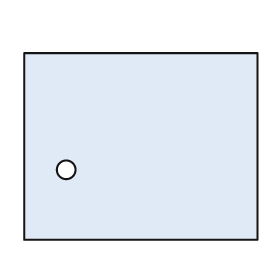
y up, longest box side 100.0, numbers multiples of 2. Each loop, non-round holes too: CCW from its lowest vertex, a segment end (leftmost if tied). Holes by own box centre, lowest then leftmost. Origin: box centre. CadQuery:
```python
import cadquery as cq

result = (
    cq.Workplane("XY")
    .moveTo(-50.0, -40.0)
    .lineTo(50.0, -40.0)
    .lineTo(50.0, 40.0)
    .lineTo(-50.0, 40.0)
    .close()
    .moveTo(-32.0, -10.0)
    .circle(4.0)
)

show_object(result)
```